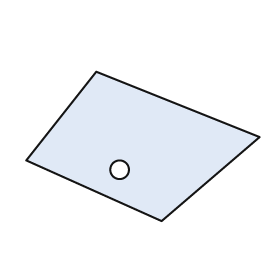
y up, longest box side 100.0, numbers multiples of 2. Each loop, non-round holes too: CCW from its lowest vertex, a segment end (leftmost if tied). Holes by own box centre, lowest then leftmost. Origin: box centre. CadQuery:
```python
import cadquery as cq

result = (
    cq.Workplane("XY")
    .moveTo(8.0, -32.0)
    .lineTo(50.0, 4.0)
    .lineTo(-20.0, 32.0)
    .lineTo(-50.0, -6.0)
    .close()
    .moveTo(-10.0, -10.0)
    .circle(4.0)
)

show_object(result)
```